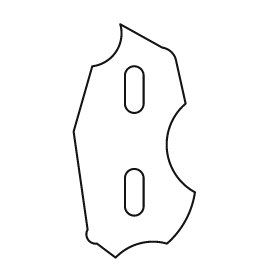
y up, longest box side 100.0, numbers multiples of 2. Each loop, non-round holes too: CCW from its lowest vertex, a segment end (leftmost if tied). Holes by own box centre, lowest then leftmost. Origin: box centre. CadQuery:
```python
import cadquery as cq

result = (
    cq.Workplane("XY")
    .moveTo(-8.0, -50.0)
    .threePointArc((2.0, -44.0), (14.0, -44.0))
    .threePointArc((22.0, -34.0), (26.0, -22.0))
    .threePointArc((14.0, -4.0), (22.0, 16.0))
    .lineTo(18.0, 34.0)
    .threePointArc((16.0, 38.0), (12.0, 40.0))
    .lineTo(-6.0, 50.0)
    .threePointArc((-8.0, 38.0), (-18.0, 32.0))
    .lineTo(-26.0, 4.0)
    .lineTo(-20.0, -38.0)
    .threePointArc((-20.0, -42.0), (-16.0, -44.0))
    .close()
    .moveTo(-4.0, -28.0)
    .threePointArc((0.0, -32.0), (4.0, -28.0))
    .lineTo(4.0, -16.0)
    .threePointArc((0.0, -12.0), (-4.0, -16.0))
    .close()
    .moveTo(-4.0, 16.0)
    .threePointArc((0.0, 12.0), (4.0, 16.0))
    .lineTo(4.0, 28.0)
    .threePointArc((0.0, 32.0), (-4.0, 28.0))
    .close()
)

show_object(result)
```